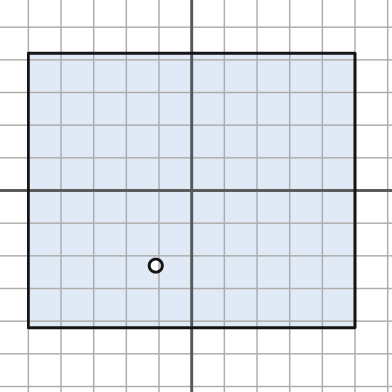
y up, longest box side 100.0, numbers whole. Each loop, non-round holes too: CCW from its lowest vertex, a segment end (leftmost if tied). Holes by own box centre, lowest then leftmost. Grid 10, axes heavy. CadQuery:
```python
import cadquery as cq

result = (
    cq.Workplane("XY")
    .moveTo(-50.0, -42.0)
    .lineTo(50.0, -42.0)
    .lineTo(50.0, 42.0)
    .lineTo(-50.0, 42.0)
    .close()
    .moveTo(-11.0, -23.0)
    .circle(2.0)
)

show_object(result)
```